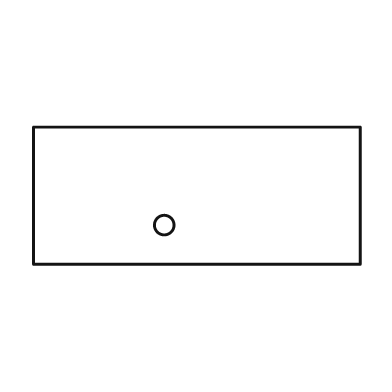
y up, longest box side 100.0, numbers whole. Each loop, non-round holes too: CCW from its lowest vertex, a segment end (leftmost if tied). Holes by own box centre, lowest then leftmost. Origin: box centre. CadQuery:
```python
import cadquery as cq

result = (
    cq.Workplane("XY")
    .moveTo(-50.0, -21.0)
    .lineTo(50.0, -21.0)
    .lineTo(50.0, 21.0)
    .lineTo(-50.0, 21.0)
    .close()
    .moveTo(-10.0, -9.0)
    .circle(3.0)
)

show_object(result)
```